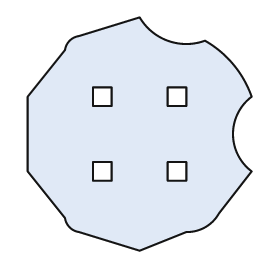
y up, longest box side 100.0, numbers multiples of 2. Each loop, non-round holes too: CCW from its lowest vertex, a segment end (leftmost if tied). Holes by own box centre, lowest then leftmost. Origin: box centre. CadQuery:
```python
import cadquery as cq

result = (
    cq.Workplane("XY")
    .moveTo(0.0, -50.0)
    .lineTo(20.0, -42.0)
    .threePointArc((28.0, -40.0), (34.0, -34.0))
    .lineTo(48.0, -16.0)
    .threePointArc((40.0, 0.0), (48.0, 16.0))
    .threePointArc((40.0, 30.0), (28.0, 40.0))
    .threePointArc((12.0, 40.0), (0.0, 50.0))
    .lineTo(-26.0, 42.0)
    .threePointArc((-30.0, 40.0), (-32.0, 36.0))
    .lineTo(-48.0, 16.0)
    .lineTo(-48.0, -16.0)
    .lineTo(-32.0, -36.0)
    .threePointArc((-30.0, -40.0), (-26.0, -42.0))
    .close()
    .moveTo(-20.0, -20.0)
    .lineTo(-12.0, -20.0)
    .lineTo(-12.0, -12.0)
    .lineTo(-20.0, -12.0)
    .close()
    .moveTo(12.0, -20.0)
    .lineTo(20.0, -20.0)
    .lineTo(20.0, -12.0)
    .lineTo(12.0, -12.0)
    .close()
    .moveTo(-20.0, 12.0)
    .lineTo(-12.0, 12.0)
    .lineTo(-12.0, 20.0)
    .lineTo(-20.0, 20.0)
    .close()
    .moveTo(12.0, 12.0)
    .lineTo(20.0, 12.0)
    .lineTo(20.0, 20.0)
    .lineTo(12.0, 20.0)
    .close()
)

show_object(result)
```